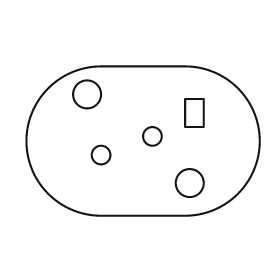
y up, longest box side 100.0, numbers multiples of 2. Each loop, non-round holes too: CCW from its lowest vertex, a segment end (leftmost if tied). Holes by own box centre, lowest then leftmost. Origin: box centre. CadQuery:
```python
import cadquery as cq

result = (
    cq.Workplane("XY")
    .moveTo(-18.0, -32.0)
    .lineTo(18.0, -32.0)
    .threePointArc((50.0, 0.0), (18.0, 32.0))
    .lineTo(-18.0, 32.0)
    .threePointArc((-50.0, 0.0), (-18.0, -32.0))
    .close()
    .moveTo(20.0, -18.0)
    .circle(6.0)
    .moveTo(-18.0, -6.0)
    .circle(4.0)
    .moveTo(4.0, 2.0)
    .circle(4.0)
    .moveTo(18.0, 6.0)
    .lineTo(26.0, 6.0)
    .lineTo(26.0, 18.0)
    .lineTo(18.0, 18.0)
    .close()
    .moveTo(-24.0, 20.0)
    .circle(6.0)
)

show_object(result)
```